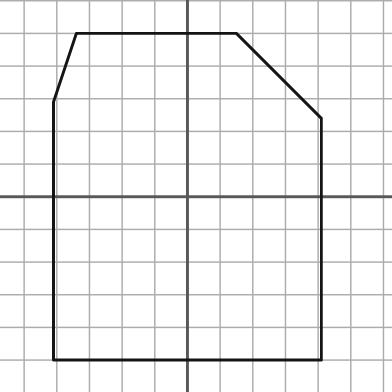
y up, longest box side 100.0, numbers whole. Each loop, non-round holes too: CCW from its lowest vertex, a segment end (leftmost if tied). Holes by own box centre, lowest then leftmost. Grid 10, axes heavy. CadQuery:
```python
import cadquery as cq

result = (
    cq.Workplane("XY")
    .moveTo(-41.0, -50.0)
    .lineTo(41.0, -50.0)
    .lineTo(41.0, 24.0)
    .lineTo(15.0, 50.0)
    .lineTo(-34.0, 50.0)
    .lineTo(-41.0, 29.0)
    .close()
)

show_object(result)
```